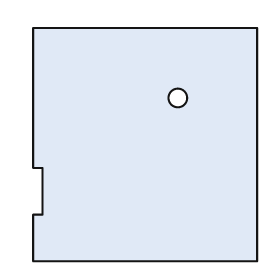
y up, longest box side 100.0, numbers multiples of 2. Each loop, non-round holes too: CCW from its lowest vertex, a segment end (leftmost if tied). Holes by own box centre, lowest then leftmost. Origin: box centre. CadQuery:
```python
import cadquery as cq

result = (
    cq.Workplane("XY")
    .moveTo(-48.0, -50.0)
    .lineTo(48.0, -50.0)
    .lineTo(48.0, 50.0)
    .lineTo(-48.0, 50.0)
    .lineTo(-48.0, -10.0)
    .lineTo(-44.0, -10.0)
    .lineTo(-44.0, -30.0)
    .lineTo(-48.0, -30.0)
    .close()
    .moveTo(14.0, 20.0)
    .circle(4.0)
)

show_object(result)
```